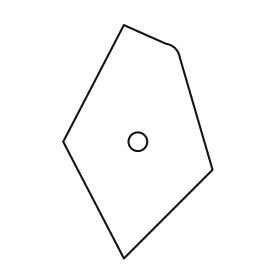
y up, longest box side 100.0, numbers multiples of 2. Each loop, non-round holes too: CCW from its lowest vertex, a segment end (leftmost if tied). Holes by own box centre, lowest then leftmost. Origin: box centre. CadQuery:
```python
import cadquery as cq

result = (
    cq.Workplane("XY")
    .moveTo(-6.0, -50.0)
    .lineTo(32.0, -12.0)
    .lineTo(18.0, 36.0)
    .threePointArc((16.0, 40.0), (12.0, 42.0))
    .lineTo(-6.0, 50.0)
    .lineTo(-32.0, 0.0)
    .close()
    .moveTo(0.0, 0.0)
    .circle(4.0)
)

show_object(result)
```